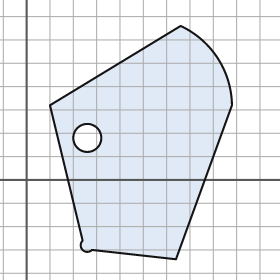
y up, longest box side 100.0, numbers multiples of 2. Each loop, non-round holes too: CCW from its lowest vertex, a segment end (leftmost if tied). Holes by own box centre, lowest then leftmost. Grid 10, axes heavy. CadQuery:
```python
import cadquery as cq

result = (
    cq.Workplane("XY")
    .moveTo(64.0, -34.0)
    .lineTo(88.0, 32.0)
    .threePointArc((82.0, 52.0), (66.0, 66.0))
    .lineTo(10.0, 32.0)
    .lineTo(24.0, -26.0)
    .threePointArc((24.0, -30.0), (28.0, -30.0))
    .close()
    .moveTo(26.0, 18.0)
    .circle(6.0)
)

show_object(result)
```